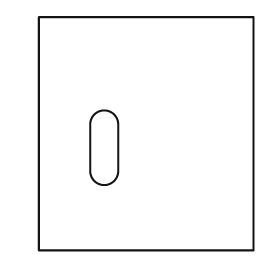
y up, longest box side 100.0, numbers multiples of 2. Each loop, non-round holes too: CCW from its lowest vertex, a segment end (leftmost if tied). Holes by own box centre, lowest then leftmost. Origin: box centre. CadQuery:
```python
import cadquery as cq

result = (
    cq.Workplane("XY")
    .moveTo(-46.0, -50.0)
    .lineTo(46.0, -50.0)
    .lineTo(46.0, 50.0)
    .lineTo(-46.0, 50.0)
    .close()
    .moveTo(-24.0, -16.0)
    .threePointArc((-18.0, -22.0), (-12.0, -16.0))
    .lineTo(-12.0, 4.0)
    .threePointArc((-18.0, 10.0), (-24.0, 4.0))
    .close()
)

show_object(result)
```